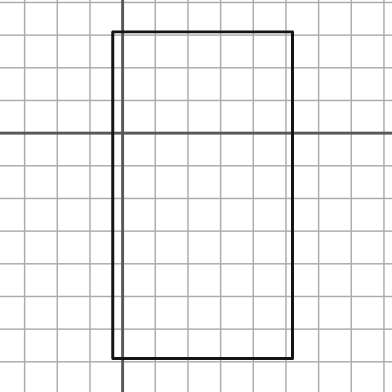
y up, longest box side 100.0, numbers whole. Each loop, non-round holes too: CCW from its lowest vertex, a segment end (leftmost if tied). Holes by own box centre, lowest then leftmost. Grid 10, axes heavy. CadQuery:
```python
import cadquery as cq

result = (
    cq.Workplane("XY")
    .moveTo(-3.0, -69.0)
    .lineTo(52.0, -69.0)
    .lineTo(52.0, 31.0)
    .lineTo(-3.0, 31.0)
    .close()
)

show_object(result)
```